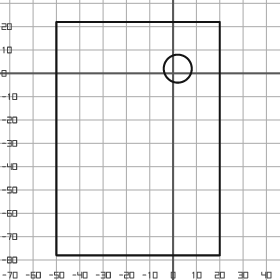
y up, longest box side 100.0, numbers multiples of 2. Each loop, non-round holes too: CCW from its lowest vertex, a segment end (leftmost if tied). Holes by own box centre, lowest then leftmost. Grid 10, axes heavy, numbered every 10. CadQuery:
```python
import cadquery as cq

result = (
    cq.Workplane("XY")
    .moveTo(-50.0, -78.0)
    .lineTo(20.0, -78.0)
    .lineTo(20.0, 22.0)
    .lineTo(-50.0, 22.0)
    .close()
    .moveTo(2.0, 2.0)
    .circle(6.0)
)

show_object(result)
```